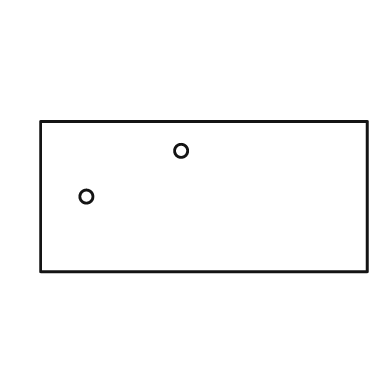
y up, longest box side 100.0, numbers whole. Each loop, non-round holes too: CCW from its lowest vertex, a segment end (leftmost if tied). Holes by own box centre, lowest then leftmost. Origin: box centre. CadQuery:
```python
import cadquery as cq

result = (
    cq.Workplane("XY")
    .moveTo(-50.0, -23.0)
    .lineTo(50.0, -23.0)
    .lineTo(50.0, 23.0)
    .lineTo(-50.0, 23.0)
    .close()
    .moveTo(-36.0, 0.0)
    .circle(2.0)
    .moveTo(-7.0, 14.0)
    .circle(2.0)
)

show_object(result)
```